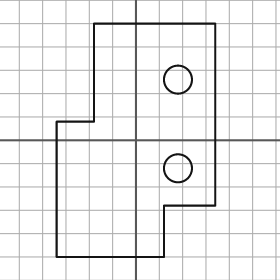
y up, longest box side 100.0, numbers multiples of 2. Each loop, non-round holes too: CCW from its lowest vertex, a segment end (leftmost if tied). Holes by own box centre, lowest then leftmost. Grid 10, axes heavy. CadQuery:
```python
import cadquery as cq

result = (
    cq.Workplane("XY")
    .moveTo(-34.0, -50.0)
    .lineTo(12.0, -50.0)
    .lineTo(12.0, -28.0)
    .lineTo(34.0, -28.0)
    .lineTo(34.0, 50.0)
    .lineTo(-18.0, 50.0)
    .lineTo(-18.0, 8.0)
    .lineTo(-34.0, 8.0)
    .close()
    .moveTo(18.0, -12.0)
    .circle(6.0)
    .moveTo(18.0, 26.0)
    .circle(6.0)
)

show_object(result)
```